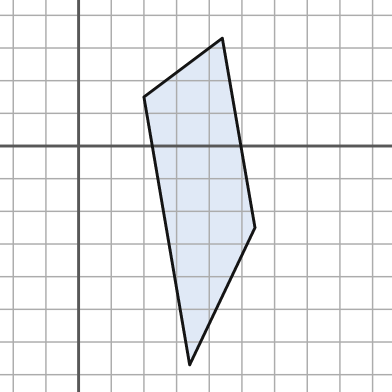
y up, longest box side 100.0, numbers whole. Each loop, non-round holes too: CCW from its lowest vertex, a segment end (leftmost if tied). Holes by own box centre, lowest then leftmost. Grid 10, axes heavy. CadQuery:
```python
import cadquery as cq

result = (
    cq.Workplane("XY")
    .moveTo(34.0, -67.0)
    .lineTo(54.0, -25.0)
    .lineTo(44.0, 33.0)
    .lineTo(20.0, 15.0)
    .close()
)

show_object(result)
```